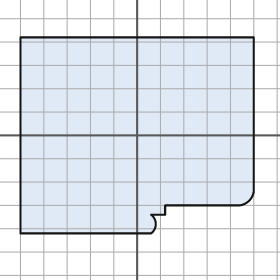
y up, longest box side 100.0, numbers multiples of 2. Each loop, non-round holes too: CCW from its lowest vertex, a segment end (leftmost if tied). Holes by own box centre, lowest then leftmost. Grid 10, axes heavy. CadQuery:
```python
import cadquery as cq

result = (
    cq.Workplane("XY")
    .moveTo(-50.0, -42.0)
    .lineTo(6.0, -42.0)
    .threePointArc((8.0, -38.0), (6.0, -34.0))
    .lineTo(12.0, -34.0)
    .lineTo(12.0, -30.0)
    .lineTo(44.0, -30.0)
    .threePointArc((48.0, -28.0), (50.0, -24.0))
    .lineTo(50.0, 42.0)
    .lineTo(-50.0, 42.0)
    .close()
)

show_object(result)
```